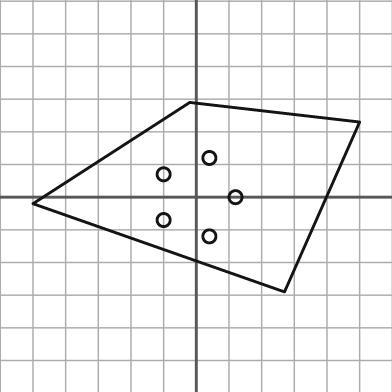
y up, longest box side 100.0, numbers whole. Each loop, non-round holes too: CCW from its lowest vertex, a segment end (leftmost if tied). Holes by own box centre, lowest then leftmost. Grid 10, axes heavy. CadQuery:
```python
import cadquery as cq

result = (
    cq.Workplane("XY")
    .moveTo(27.0, -29.0)
    .lineTo(50.0, 23.0)
    .lineTo(-2.0, 29.0)
    .lineTo(-50.0, -2.0)
    .close()
    .moveTo(4.0, -12.0)
    .circle(2.0)
    .moveTo(-10.0, -7.0)
    .circle(2.0)
    .moveTo(12.0, 0.0)
    .circle(2.0)
    .moveTo(-10.0, 7.0)
    .circle(2.0)
    .moveTo(4.0, 12.0)
    .circle(2.0)
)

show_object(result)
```